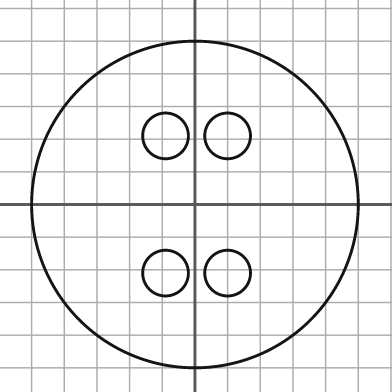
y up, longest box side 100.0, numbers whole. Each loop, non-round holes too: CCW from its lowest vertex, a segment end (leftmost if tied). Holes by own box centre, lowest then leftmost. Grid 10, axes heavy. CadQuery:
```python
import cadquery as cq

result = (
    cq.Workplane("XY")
    .moveTo(0.0, 0.0)
    .circle(50.0)
    .moveTo(-9.0, -21.0)
    .circle(7.0)
    .moveTo(10.0, -21.0)
    .circle(7.0)
    .moveTo(-9.0, 21.0)
    .circle(7.0)
    .moveTo(10.0, 21.0)
    .circle(7.0)
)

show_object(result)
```